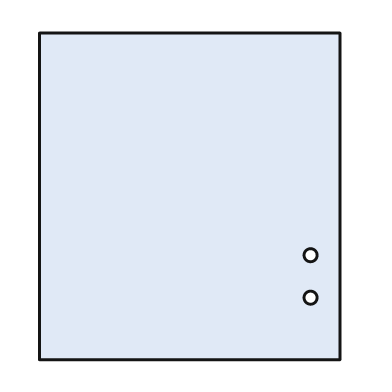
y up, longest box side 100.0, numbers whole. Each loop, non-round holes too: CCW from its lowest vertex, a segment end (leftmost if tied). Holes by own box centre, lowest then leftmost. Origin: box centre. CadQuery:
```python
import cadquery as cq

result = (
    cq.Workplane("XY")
    .moveTo(-46.0, -50.0)
    .lineTo(46.0, -50.0)
    .lineTo(46.0, 50.0)
    .lineTo(-46.0, 50.0)
    .close()
    .moveTo(37.0, -31.0)
    .circle(2.0)
    .moveTo(37.0, -18.0)
    .circle(2.0)
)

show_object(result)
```